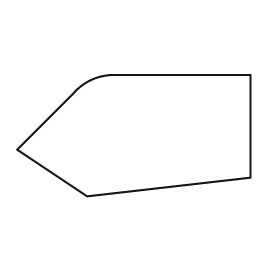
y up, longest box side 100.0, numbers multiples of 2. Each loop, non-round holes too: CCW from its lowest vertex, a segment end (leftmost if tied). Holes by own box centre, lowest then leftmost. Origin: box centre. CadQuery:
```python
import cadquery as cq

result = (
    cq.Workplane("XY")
    .moveTo(-20.0, -26.0)
    .lineTo(50.0, -18.0)
    .lineTo(50.0, 26.0)
    .lineTo(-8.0, 26.0)
    .threePointArc((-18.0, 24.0), (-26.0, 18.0))
    .lineTo(-50.0, -6.0)
    .close()
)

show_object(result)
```